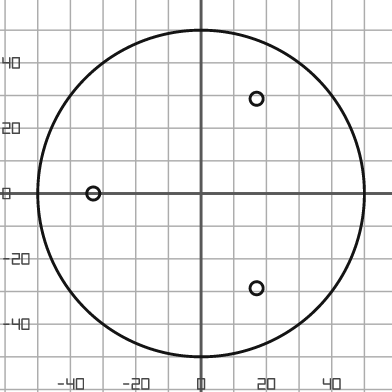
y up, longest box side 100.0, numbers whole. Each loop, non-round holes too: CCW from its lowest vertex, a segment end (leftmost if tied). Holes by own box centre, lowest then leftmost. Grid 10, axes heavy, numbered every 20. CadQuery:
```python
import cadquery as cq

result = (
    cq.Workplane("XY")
    .moveTo(0.0, 0.0)
    .circle(50.0)
    .moveTo(17.0, -29.0)
    .circle(2.0)
    .moveTo(-33.0, 0.0)
    .circle(2.0)
    .moveTo(17.0, 29.0)
    .circle(2.0)
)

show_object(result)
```